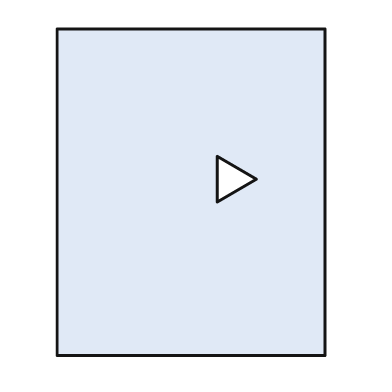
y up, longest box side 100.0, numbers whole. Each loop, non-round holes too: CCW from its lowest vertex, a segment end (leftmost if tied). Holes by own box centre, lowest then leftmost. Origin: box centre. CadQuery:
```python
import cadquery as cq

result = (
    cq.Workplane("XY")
    .moveTo(-41.0, -50.0)
    .lineTo(41.0, -50.0)
    .lineTo(41.0, 50.0)
    .lineTo(-41.0, 50.0)
    .close()
    .moveTo(8.0, -3.0)
    .lineTo(20.0, 4.0)
    .lineTo(8.0, 11.0)
    .close()
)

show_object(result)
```